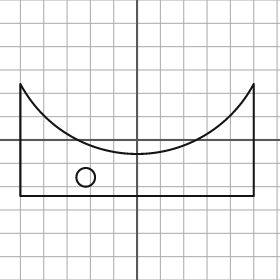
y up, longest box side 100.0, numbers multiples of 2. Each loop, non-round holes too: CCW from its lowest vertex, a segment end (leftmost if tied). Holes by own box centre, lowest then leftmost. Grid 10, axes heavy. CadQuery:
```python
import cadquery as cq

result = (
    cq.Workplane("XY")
    .moveTo(-50.0, -24.0)
    .lineTo(50.0, -24.0)
    .lineTo(50.0, 24.0)
    .threePointArc((0.0, -6.0), (-50.0, 24.0))
    .close()
    .moveTo(-22.0, -16.0)
    .circle(4.0)
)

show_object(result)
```